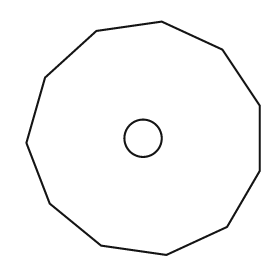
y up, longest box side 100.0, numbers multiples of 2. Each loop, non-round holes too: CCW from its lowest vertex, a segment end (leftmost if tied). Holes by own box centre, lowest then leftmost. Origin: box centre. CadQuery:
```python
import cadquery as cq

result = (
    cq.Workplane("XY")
    .moveTo(10.0, -50.0)
    .lineTo(36.0, -38.0)
    .lineTo(50.0, -14.0)
    .lineTo(50.0, 14.0)
    .lineTo(34.0, 38.0)
    .lineTo(8.0, 50.0)
    .lineTo(-20.0, 46.0)
    .lineTo(-42.0, 26.0)
    .lineTo(-50.0, -2.0)
    .lineTo(-40.0, -28.0)
    .lineTo(-18.0, -46.0)
    .close()
    .moveTo(0.0, 0.0)
    .circle(8.0)
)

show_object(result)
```